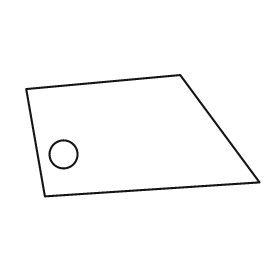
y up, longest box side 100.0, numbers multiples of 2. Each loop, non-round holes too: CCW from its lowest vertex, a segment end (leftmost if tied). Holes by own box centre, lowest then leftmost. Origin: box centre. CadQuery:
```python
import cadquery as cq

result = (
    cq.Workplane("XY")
    .moveTo(-42.0, -26.0)
    .lineTo(50.0, -20.0)
    .lineTo(16.0, 26.0)
    .lineTo(-50.0, 20.0)
    .close()
    .moveTo(-34.0, -8.0)
    .circle(6.0)
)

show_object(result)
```